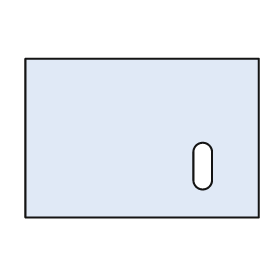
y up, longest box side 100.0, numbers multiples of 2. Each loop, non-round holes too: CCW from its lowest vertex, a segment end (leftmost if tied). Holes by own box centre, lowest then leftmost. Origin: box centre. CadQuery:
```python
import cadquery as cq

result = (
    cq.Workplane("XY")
    .moveTo(-50.0, -34.0)
    .lineTo(50.0, -34.0)
    .lineTo(50.0, 34.0)
    .lineTo(-50.0, 34.0)
    .close()
    .moveTo(22.0, -18.0)
    .threePointArc((26.0, -22.0), (30.0, -18.0))
    .lineTo(30.0, -6.0)
    .threePointArc((26.0, -2.0), (22.0, -6.0))
    .close()
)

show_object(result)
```